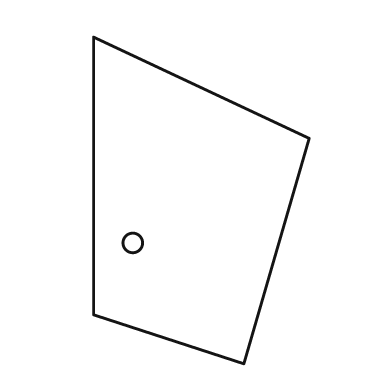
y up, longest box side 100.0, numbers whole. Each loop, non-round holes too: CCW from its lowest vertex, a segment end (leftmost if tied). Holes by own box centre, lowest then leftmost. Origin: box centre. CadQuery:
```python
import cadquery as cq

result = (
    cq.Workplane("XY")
    .moveTo(13.0, -50.0)
    .lineTo(33.0, 19.0)
    .lineTo(-33.0, 50.0)
    .lineTo(-33.0, -35.0)
    .close()
    .moveTo(-21.0, -13.0)
    .circle(3.0)
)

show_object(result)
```